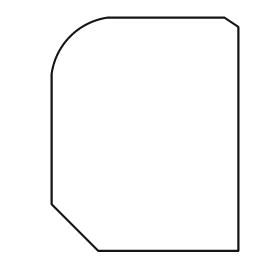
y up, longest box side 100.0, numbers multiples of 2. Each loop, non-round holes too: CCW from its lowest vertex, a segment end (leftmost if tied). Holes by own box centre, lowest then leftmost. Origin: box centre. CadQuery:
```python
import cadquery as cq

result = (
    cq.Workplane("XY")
    .moveTo(-20.0, -50.0)
    .lineTo(40.0, -50.0)
    .lineTo(40.0, 46.0)
    .lineTo(34.0, 50.0)
    .lineTo(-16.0, 50.0)
    .threePointArc((-32.0, 42.0), (-40.0, 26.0))
    .lineTo(-40.0, -30.0)
    .close()
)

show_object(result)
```